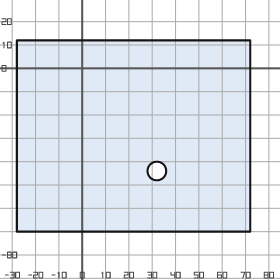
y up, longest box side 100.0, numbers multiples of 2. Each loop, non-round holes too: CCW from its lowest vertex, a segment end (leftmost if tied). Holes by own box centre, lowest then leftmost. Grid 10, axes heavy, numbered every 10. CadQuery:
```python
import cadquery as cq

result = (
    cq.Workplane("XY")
    .moveTo(-28.0, -70.0)
    .lineTo(72.0, -70.0)
    .lineTo(72.0, 12.0)
    .lineTo(-28.0, 12.0)
    .close()
    .moveTo(32.0, -44.0)
    .circle(4.0)
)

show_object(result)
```